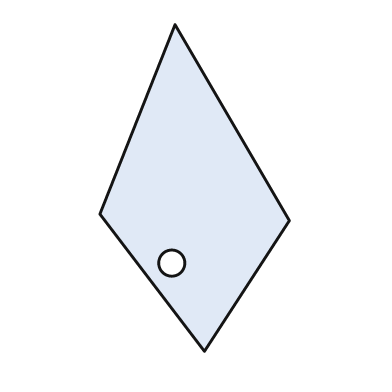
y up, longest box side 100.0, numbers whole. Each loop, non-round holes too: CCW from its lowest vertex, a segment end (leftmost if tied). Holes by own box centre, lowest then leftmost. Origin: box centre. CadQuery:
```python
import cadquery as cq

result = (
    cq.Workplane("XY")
    .moveTo(3.0, -50.0)
    .lineTo(29.0, -10.0)
    .lineTo(-6.0, 50.0)
    .lineTo(-29.0, -8.0)
    .close()
    .moveTo(-7.0, -23.0)
    .circle(4.0)
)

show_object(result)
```